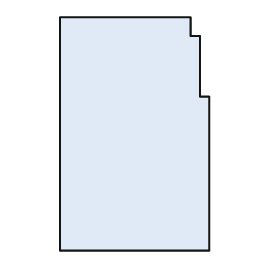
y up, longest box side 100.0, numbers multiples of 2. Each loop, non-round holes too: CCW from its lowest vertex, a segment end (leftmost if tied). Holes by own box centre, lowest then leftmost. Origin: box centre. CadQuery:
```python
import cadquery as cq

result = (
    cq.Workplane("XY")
    .moveTo(-32.0, -50.0)
    .lineTo(32.0, -50.0)
    .lineTo(32.0, 16.0)
    .lineTo(28.0, 16.0)
    .lineTo(28.0, 42.0)
    .lineTo(24.0, 42.0)
    .lineTo(24.0, 50.0)
    .lineTo(-32.0, 50.0)
    .close()
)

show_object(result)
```